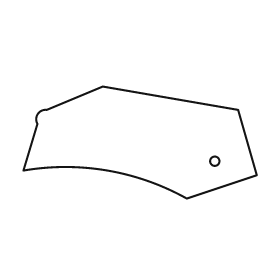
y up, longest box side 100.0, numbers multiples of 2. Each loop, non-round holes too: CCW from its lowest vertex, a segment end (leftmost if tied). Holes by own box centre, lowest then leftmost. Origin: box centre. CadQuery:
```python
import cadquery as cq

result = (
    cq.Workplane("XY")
    .moveTo(20.0, -24.0)
    .lineTo(50.0, -14.0)
    .lineTo(42.0, 14.0)
    .lineTo(-16.0, 24.0)
    .lineTo(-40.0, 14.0)
    .threePointArc((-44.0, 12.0), (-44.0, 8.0))
    .lineTo(-50.0, -12.0)
    .threePointArc((-14.0, -12.0), (20.0, -24.0))
    .close()
    .moveTo(32.0, -8.0)
    .circle(2.0)
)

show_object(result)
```